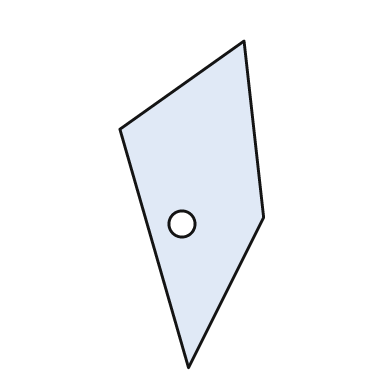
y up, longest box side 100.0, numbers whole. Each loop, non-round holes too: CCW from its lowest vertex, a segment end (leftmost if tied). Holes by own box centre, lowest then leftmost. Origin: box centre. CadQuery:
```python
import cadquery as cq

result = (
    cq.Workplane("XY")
    .moveTo(-1.0, -50.0)
    .lineTo(22.0, -4.0)
    .lineTo(16.0, 50.0)
    .lineTo(-22.0, 23.0)
    .close()
    .moveTo(-3.0, -6.0)
    .circle(4.0)
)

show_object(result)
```